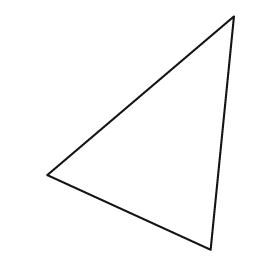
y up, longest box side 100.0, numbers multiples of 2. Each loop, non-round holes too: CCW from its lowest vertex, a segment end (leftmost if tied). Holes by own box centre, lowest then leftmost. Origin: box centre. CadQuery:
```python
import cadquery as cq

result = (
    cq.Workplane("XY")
    .moveTo(30.0, -50.0)
    .lineTo(40.0, 50.0)
    .lineTo(-40.0, -18.0)
    .close()
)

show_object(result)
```